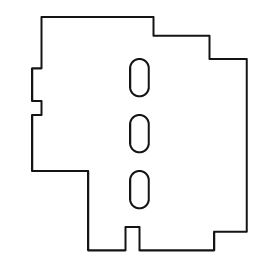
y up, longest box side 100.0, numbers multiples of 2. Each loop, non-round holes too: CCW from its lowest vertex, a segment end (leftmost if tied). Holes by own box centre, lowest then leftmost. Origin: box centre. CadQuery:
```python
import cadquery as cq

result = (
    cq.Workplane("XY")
    .moveTo(-22.0, -50.0)
    .lineTo(-6.0, -50.0)
    .lineTo(-6.0, -40.0)
    .lineTo(0.0, -40.0)
    .lineTo(0.0, -50.0)
    .lineTo(32.0, -50.0)
    .lineTo(32.0, -42.0)
    .lineTo(46.0, -42.0)
    .lineTo(46.0, 32.0)
    .lineTo(30.0, 32.0)
    .lineTo(30.0, 42.0)
    .lineTo(6.0, 42.0)
    .lineTo(6.0, 50.0)
    .lineTo(-42.0, 50.0)
    .lineTo(-42.0, 28.0)
    .lineTo(-46.0, 28.0)
    .lineTo(-46.0, 14.0)
    .lineTo(-42.0, 14.0)
    .lineTo(-42.0, 8.0)
    .lineTo(-46.0, 8.0)
    .lineTo(-46.0, -16.0)
    .lineTo(-22.0, -16.0)
    .close()
    .moveTo(-4.0, -28.0)
    .threePointArc((0.0, -32.0), (4.0, -28.0))
    .lineTo(4.0, -20.0)
    .threePointArc((0.0, -16.0), (-4.0, -20.0))
    .close()
    .moveTo(-4.0, -4.0)
    .threePointArc((0.0, -8.0), (4.0, -4.0))
    .lineTo(4.0, 4.0)
    .threePointArc((0.0, 8.0), (-4.0, 4.0))
    .close()
    .moveTo(-4.0, 20.0)
    .threePointArc((0.0, 16.0), (4.0, 20.0))
    .lineTo(4.0, 28.0)
    .threePointArc((0.0, 32.0), (-4.0, 28.0))
    .close()
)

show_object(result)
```